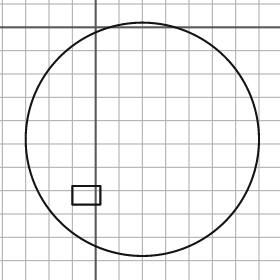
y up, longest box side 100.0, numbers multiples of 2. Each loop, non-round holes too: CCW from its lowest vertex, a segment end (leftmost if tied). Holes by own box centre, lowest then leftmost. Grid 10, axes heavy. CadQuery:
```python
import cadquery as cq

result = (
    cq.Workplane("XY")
    .moveTo(20.0, -48.0)
    .circle(50.0)
    .moveTo(-10.0, -76.0)
    .lineTo(2.0, -76.0)
    .lineTo(2.0, -68.0)
    .lineTo(-10.0, -68.0)
    .close()
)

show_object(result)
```